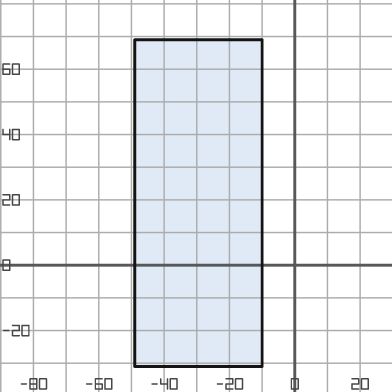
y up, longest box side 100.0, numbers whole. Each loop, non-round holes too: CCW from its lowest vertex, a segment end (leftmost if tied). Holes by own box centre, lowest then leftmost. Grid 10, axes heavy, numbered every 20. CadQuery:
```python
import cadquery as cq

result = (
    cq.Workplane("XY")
    .moveTo(-49.0, -31.0)
    .lineTo(-10.0, -31.0)
    .lineTo(-10.0, 69.0)
    .lineTo(-49.0, 69.0)
    .close()
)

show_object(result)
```